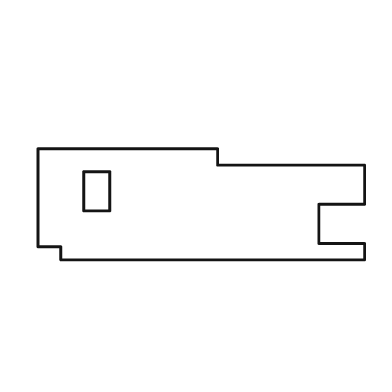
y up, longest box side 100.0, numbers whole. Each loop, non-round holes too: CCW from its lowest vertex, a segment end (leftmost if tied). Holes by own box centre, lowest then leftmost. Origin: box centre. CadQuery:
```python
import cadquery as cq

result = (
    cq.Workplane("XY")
    .moveTo(-43.0, -17.0)
    .lineTo(50.0, -17.0)
    .lineTo(50.0, -12.0)
    .lineTo(36.0, -12.0)
    .lineTo(36.0, 0.0)
    .lineTo(50.0, 0.0)
    .lineTo(50.0, 12.0)
    .lineTo(5.0, 12.0)
    .lineTo(5.0, 17.0)
    .lineTo(-50.0, 17.0)
    .lineTo(-50.0, -13.0)
    .lineTo(-43.0, -13.0)
    .close()
    .moveTo(-36.0, -2.0)
    .lineTo(-28.0, -2.0)
    .lineTo(-28.0, 10.0)
    .lineTo(-36.0, 10.0)
    .close()
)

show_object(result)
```